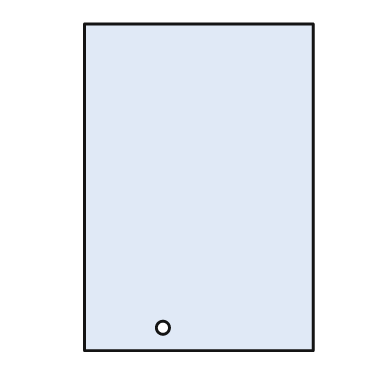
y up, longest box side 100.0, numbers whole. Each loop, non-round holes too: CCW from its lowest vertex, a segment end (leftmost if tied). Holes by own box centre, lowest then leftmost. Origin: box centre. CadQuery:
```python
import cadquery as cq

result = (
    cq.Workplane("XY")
    .moveTo(-35.0, -50.0)
    .lineTo(35.0, -50.0)
    .lineTo(35.0, 50.0)
    .lineTo(-35.0, 50.0)
    .close()
    .moveTo(-11.0, -43.0)
    .circle(2.0)
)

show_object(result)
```